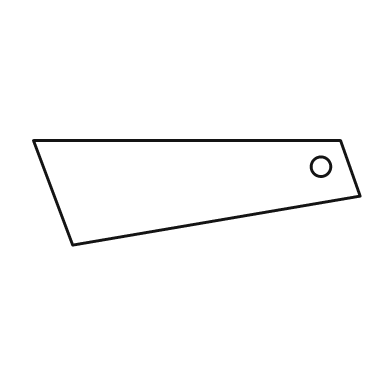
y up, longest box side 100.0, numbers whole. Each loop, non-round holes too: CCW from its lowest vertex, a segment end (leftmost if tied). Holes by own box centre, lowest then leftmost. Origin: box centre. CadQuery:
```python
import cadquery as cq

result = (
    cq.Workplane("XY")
    .moveTo(-38.0, -16.0)
    .lineTo(50.0, -1.0)
    .lineTo(44.0, 16.0)
    .lineTo(-50.0, 16.0)
    .close()
    .moveTo(38.0, 8.0)
    .circle(3.0)
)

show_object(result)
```